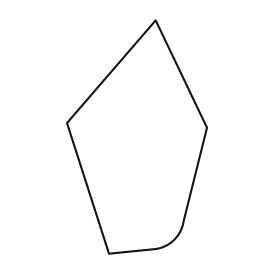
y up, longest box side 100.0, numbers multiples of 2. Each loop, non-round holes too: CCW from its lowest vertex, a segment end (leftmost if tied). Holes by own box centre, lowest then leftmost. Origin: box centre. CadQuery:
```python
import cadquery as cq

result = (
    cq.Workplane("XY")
    .moveTo(-12.0, -50.0)
    .lineTo(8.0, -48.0)
    .threePointArc((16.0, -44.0), (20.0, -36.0))
    .lineTo(30.0, 4.0)
    .lineTo(8.0, 50.0)
    .lineTo(-30.0, 6.0)
    .close()
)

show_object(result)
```